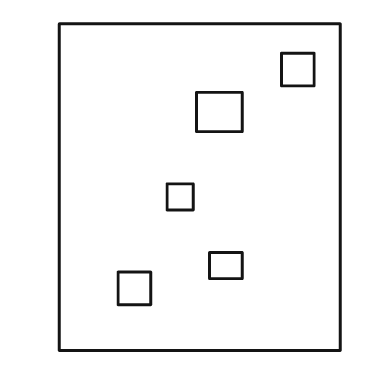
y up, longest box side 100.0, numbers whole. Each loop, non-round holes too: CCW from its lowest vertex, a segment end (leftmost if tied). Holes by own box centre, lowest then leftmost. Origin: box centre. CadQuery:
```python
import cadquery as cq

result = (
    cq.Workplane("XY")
    .moveTo(-43.0, -50.0)
    .lineTo(43.0, -50.0)
    .lineTo(43.0, 50.0)
    .lineTo(-43.0, 50.0)
    .close()
    .moveTo(-25.0, -36.0)
    .lineTo(-15.0, -36.0)
    .lineTo(-15.0, -26.0)
    .lineTo(-25.0, -26.0)
    .close()
    .moveTo(3.0, -28.0)
    .lineTo(13.0, -28.0)
    .lineTo(13.0, -20.0)
    .lineTo(3.0, -20.0)
    .close()
    .moveTo(-10.0, -7.0)
    .lineTo(-2.0, -7.0)
    .lineTo(-2.0, 1.0)
    .lineTo(-10.0, 1.0)
    .close()
    .moveTo(-1.0, 17.0)
    .lineTo(13.0, 17.0)
    .lineTo(13.0, 29.0)
    .lineTo(-1.0, 29.0)
    .close()
    .moveTo(25.0, 31.0)
    .lineTo(35.0, 31.0)
    .lineTo(35.0, 41.0)
    .lineTo(25.0, 41.0)
    .close()
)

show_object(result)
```